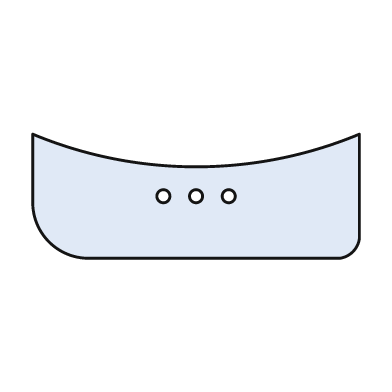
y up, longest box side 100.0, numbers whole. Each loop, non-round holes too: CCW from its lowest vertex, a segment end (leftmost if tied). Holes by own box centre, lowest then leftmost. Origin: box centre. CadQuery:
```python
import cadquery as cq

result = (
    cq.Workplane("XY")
    .moveTo(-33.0, -19.0)
    .lineTo(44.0, -19.0)
    .threePointArc((48.0, -17.0), (50.0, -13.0))
    .lineTo(50.0, 19.0)
    .threePointArc((0.0, 9.0), (-50.0, 19.0))
    .lineTo(-50.0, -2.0)
    .threePointArc((-45.0, -14.0), (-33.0, -19.0))
    .close()
    .moveTo(-10.0, 0.0)
    .circle(2.0)
    .moveTo(0.0, 0.0)
    .circle(2.0)
    .moveTo(10.0, 0.0)
    .circle(2.0)
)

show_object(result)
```